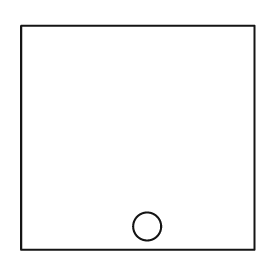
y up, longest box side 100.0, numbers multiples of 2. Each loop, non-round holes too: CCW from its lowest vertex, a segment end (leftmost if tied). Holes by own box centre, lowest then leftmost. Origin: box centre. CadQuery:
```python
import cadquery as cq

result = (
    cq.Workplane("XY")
    .moveTo(-50.0, -48.0)
    .lineTo(50.0, -48.0)
    .lineTo(50.0, 48.0)
    .lineTo(-50.0, 48.0)
    .close()
    .moveTo(4.0, -38.0)
    .circle(6.0)
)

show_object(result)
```